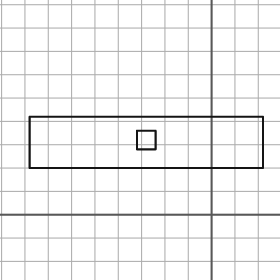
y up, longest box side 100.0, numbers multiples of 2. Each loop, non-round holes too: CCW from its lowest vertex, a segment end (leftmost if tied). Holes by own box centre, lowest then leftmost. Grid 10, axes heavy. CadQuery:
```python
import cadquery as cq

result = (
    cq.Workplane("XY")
    .moveTo(-78.0, 20.0)
    .lineTo(22.0, 20.0)
    .lineTo(22.0, 42.0)
    .lineTo(-78.0, 42.0)
    .close()
    .moveTo(-32.0, 28.0)
    .lineTo(-24.0, 28.0)
    .lineTo(-24.0, 36.0)
    .lineTo(-32.0, 36.0)
    .close()
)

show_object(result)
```